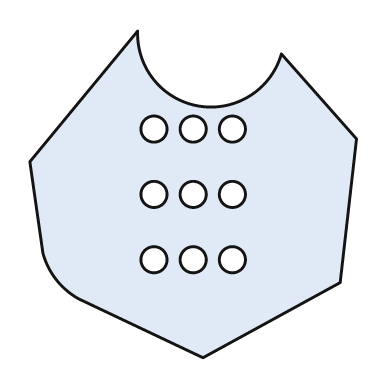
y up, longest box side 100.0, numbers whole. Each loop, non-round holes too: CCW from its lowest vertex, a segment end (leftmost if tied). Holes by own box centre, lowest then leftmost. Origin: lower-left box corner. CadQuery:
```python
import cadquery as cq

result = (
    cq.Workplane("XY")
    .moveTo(53.0, 0.0)
    .lineTo(95.0, 23.0)
    .lineTo(100.0, 67.0)
    .lineTo(77.0, 93.0)
    .threePointArc((52.0, 77.0), (33.0, 100.0))
    .lineTo(0.0, 60.0)
    .lineTo(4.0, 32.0)
    .threePointArc((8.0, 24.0), (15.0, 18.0))
    .close()
    .moveTo(38.0, 30.0)
    .circle(4.0)
    .moveTo(50.0, 30.0)
    .circle(4.0)
    .moveTo(62.0, 30.0)
    .circle(4.0)
    .moveTo(38.0, 50.0)
    .circle(4.0)
    .moveTo(50.0, 50.0)
    .circle(4.0)
    .moveTo(62.0, 50.0)
    .circle(4.0)
    .moveTo(38.0, 70.0)
    .circle(4.0)
    .moveTo(50.0, 70.0)
    .circle(4.0)
    .moveTo(62.0, 70.0)
    .circle(4.0)
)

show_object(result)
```